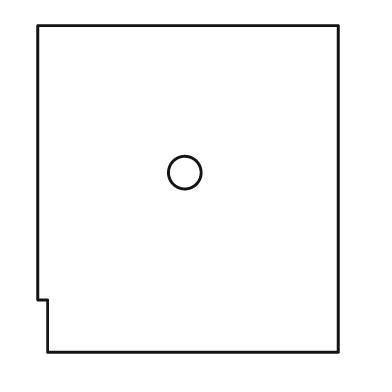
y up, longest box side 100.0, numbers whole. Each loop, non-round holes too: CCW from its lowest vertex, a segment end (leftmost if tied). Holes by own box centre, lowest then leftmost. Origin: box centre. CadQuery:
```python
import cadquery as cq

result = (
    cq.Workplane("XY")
    .moveTo(-43.0, -50.0)
    .lineTo(46.0, -50.0)
    .lineTo(46.0, 50.0)
    .lineTo(-46.0, 50.0)
    .lineTo(-46.0, -34.0)
    .lineTo(-43.0, -34.0)
    .close()
    .moveTo(-1.0, 5.0)
    .circle(5.0)
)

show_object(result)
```